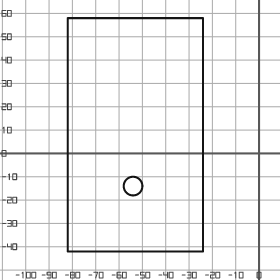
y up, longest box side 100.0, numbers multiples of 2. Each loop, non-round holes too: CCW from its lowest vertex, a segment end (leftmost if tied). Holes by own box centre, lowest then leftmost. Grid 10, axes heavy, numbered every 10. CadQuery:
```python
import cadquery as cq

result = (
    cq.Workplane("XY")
    .moveTo(-82.0, -42.0)
    .lineTo(-24.0, -42.0)
    .lineTo(-24.0, 58.0)
    .lineTo(-82.0, 58.0)
    .close()
    .moveTo(-54.0, -14.0)
    .circle(4.0)
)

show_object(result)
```